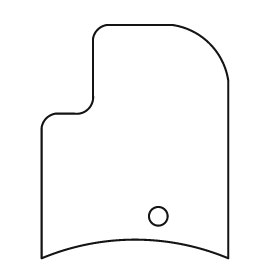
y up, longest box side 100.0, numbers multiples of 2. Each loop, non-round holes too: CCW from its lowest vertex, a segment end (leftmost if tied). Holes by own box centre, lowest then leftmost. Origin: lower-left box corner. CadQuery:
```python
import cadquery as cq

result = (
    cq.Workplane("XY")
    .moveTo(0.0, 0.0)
    .threePointArc((40.0, 8.0), (80.0, 0.0))
    .lineTo(80.0, 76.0)
    .threePointArc((72.0, 92.0), (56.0, 100.0))
    .lineTo(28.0, 100.0)
    .threePointArc((24.0, 98.0), (22.0, 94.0))
    .lineTo(22.0, 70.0)
    .threePointArc((20.0, 64.0), (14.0, 62.0))
    .lineTo(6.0, 62.0)
    .threePointArc((2.0, 60.0), (0.0, 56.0))
    .close()
    .moveTo(50.0, 18.0)
    .circle(4.0)
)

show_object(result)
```